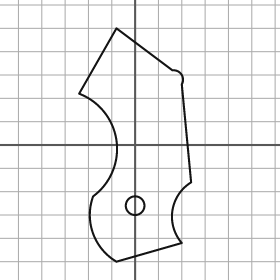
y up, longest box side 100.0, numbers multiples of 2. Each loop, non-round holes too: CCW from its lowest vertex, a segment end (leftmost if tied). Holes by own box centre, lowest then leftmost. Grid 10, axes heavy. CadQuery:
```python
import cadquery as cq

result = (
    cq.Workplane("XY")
    .moveTo(-8.0, -50.0)
    .lineTo(20.0, -42.0)
    .threePointArc((16.0, -28.0), (24.0, -16.0))
    .lineTo(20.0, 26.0)
    .threePointArc((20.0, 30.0), (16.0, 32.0))
    .lineTo(-8.0, 50.0)
    .lineTo(-24.0, 22.0)
    .threePointArc((-8.0, 2.0), (-18.0, -22.0))
    .threePointArc((-18.0, -38.0), (-8.0, -50.0))
    .close()
    .moveTo(0.0, -26.0)
    .circle(4.0)
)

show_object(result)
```